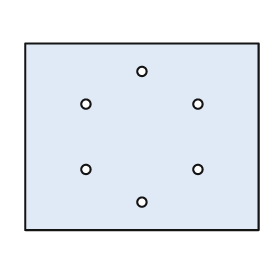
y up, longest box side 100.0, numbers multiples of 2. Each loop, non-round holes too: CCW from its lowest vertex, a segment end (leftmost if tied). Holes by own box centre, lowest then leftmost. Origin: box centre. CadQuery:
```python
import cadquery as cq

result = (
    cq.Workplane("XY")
    .moveTo(-50.0, -40.0)
    .lineTo(50.0, -40.0)
    .lineTo(50.0, 40.0)
    .lineTo(-50.0, 40.0)
    .close()
    .moveTo(0.0, -28.0)
    .circle(2.0)
    .moveTo(-24.0, -14.0)
    .circle(2.0)
    .moveTo(24.0, -14.0)
    .circle(2.0)
    .moveTo(-24.0, 14.0)
    .circle(2.0)
    .moveTo(24.0, 14.0)
    .circle(2.0)
    .moveTo(0.0, 28.0)
    .circle(2.0)
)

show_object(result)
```